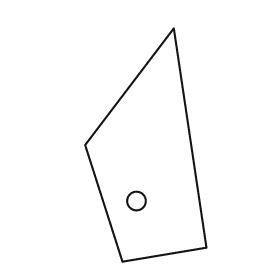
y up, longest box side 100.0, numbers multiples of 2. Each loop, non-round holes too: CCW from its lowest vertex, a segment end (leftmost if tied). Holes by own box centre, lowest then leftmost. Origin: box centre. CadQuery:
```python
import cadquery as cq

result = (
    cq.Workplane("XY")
    .moveTo(-10.0, -50.0)
    .lineTo(26.0, -44.0)
    .lineTo(12.0, 50.0)
    .lineTo(-26.0, 0.0)
    .close()
    .moveTo(-4.0, -24.0)
    .circle(4.0)
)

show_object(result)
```